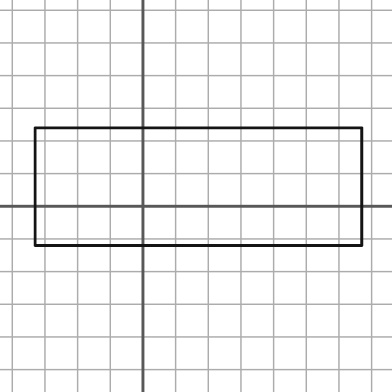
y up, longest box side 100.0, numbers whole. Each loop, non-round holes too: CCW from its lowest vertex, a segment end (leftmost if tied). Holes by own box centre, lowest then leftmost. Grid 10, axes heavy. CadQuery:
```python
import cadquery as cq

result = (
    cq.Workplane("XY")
    .moveTo(-33.0, -12.0)
    .lineTo(67.0, -12.0)
    .lineTo(67.0, 24.0)
    .lineTo(-33.0, 24.0)
    .close()
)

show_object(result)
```